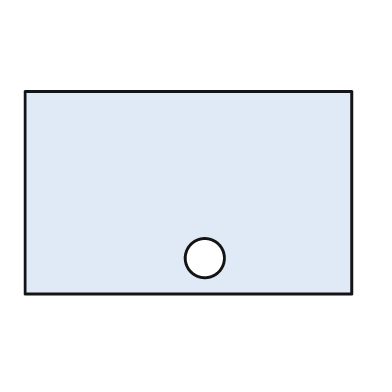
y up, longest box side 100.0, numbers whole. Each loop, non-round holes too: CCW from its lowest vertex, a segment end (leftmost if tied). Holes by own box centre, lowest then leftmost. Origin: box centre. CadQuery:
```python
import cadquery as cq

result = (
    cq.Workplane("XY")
    .moveTo(-50.0, -31.0)
    .lineTo(50.0, -31.0)
    .lineTo(50.0, 31.0)
    .lineTo(-50.0, 31.0)
    .close()
    .moveTo(5.0, -20.0)
    .circle(6.0)
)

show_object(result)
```